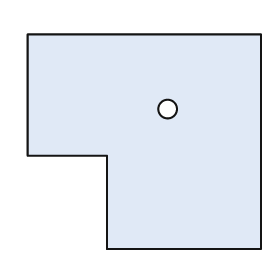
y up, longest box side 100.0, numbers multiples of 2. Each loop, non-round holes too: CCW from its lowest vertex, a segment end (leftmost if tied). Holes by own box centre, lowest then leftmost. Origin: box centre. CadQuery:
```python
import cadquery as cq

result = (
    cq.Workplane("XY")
    .moveTo(-16.0, -46.0)
    .lineTo(50.0, -46.0)
    .lineTo(50.0, 46.0)
    .lineTo(-50.0, 46.0)
    .lineTo(-50.0, -6.0)
    .lineTo(-16.0, -6.0)
    .close()
    .moveTo(10.0, 14.0)
    .circle(4.0)
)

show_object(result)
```